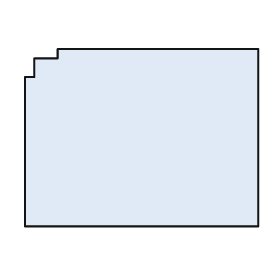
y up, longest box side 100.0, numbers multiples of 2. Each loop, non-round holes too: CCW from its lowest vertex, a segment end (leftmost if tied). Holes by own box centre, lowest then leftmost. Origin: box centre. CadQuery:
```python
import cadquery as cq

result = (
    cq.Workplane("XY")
    .moveTo(-50.0, -38.0)
    .lineTo(50.0, -38.0)
    .lineTo(50.0, 38.0)
    .lineTo(-36.0, 38.0)
    .lineTo(-36.0, 34.0)
    .lineTo(-46.0, 34.0)
    .lineTo(-46.0, 26.0)
    .lineTo(-50.0, 26.0)
    .close()
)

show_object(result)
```